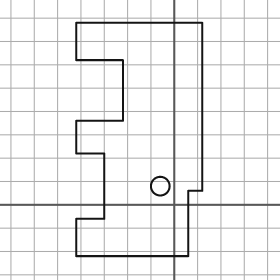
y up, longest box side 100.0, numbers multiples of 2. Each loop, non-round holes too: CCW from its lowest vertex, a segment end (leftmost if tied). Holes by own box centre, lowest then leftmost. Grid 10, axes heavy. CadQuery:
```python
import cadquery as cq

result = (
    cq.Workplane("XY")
    .moveTo(-42.0, -22.0)
    .lineTo(6.0, -22.0)
    .lineTo(6.0, 6.0)
    .lineTo(12.0, 6.0)
    .lineTo(12.0, 78.0)
    .lineTo(-42.0, 78.0)
    .lineTo(-42.0, 62.0)
    .lineTo(-22.0, 62.0)
    .lineTo(-22.0, 36.0)
    .lineTo(-42.0, 36.0)
    .lineTo(-42.0, 22.0)
    .lineTo(-30.0, 22.0)
    .lineTo(-30.0, -6.0)
    .lineTo(-42.0, -6.0)
    .close()
    .moveTo(-6.0, 8.0)
    .circle(4.0)
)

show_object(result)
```